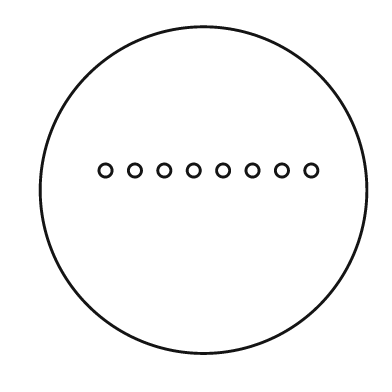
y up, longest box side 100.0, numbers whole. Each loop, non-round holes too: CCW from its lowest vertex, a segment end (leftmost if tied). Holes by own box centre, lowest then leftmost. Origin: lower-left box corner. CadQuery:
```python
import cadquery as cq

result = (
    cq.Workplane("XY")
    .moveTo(50.0, 50.0)
    .circle(50.0)
    .moveTo(20.0, 56.0)
    .circle(2.0)
    .moveTo(29.0, 56.0)
    .circle(2.0)
    .moveTo(38.0, 56.0)
    .circle(2.0)
    .moveTo(47.0, 56.0)
    .circle(2.0)
    .moveTo(56.0, 56.0)
    .circle(2.0)
    .moveTo(65.0, 56.0)
    .circle(2.0)
    .moveTo(74.0, 56.0)
    .circle(2.0)
    .moveTo(83.0, 56.0)
    .circle(2.0)
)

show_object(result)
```